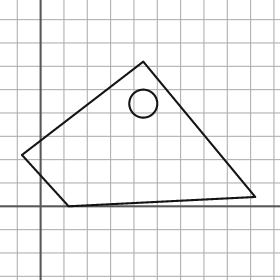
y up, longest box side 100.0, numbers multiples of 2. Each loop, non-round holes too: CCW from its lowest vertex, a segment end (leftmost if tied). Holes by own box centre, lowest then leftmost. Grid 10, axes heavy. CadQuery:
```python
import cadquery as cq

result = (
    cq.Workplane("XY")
    .moveTo(12.0, 0.0)
    .lineTo(92.0, 4.0)
    .lineTo(44.0, 62.0)
    .lineTo(-8.0, 22.0)
    .close()
    .moveTo(44.0, 44.0)
    .circle(6.0)
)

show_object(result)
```